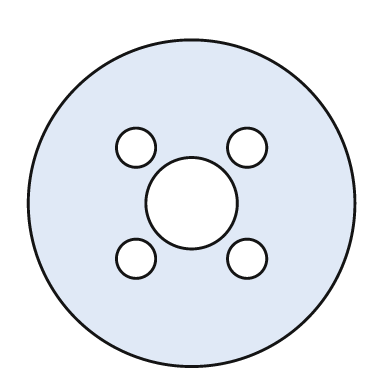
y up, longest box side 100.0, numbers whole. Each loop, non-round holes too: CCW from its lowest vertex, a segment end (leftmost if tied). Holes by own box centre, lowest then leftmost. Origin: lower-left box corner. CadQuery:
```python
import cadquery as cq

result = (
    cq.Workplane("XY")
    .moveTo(50.0, 50.0)
    .circle(50.0)
    .moveTo(33.0, 33.0)
    .circle(6.0)
    .moveTo(67.0, 33.0)
    .circle(6.0)
    .moveTo(50.0, 50.0)
    .circle(14.0)
    .moveTo(33.0, 67.0)
    .circle(6.0)
    .moveTo(67.0, 67.0)
    .circle(6.0)
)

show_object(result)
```